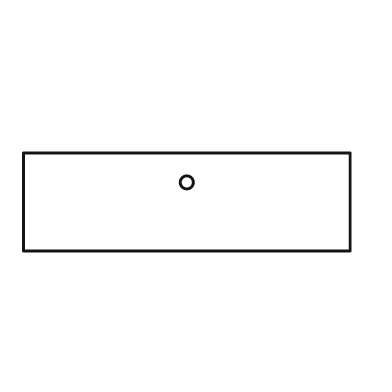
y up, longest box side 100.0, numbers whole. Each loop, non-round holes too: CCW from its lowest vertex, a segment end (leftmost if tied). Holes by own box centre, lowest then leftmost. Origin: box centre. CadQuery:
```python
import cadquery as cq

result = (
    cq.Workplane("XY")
    .moveTo(-50.0, -15.0)
    .lineTo(50.0, -15.0)
    .lineTo(50.0, 15.0)
    .lineTo(-50.0, 15.0)
    .close()
    .moveTo(0.0, 6.0)
    .circle(2.0)
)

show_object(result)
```